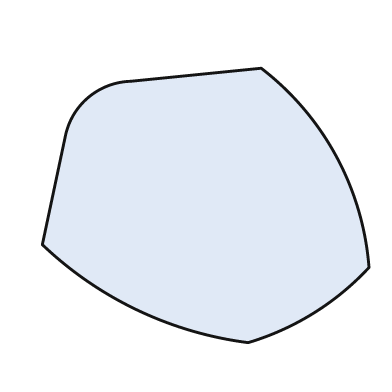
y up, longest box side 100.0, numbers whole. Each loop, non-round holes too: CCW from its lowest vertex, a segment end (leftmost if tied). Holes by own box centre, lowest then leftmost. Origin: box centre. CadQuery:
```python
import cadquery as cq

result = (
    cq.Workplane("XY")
    .moveTo(13.0, -42.0)
    .threePointArc((33.0, -33.0), (50.0, -19.0))
    .threePointArc((40.0, 15.0), (17.0, 42.0))
    .lineTo(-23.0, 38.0)
    .threePointArc((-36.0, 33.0), (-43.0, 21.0))
    .lineTo(-50.0, -12.0)
    .threePointArc((-21.0, -32.0), (13.0, -42.0))
    .close()
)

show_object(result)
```